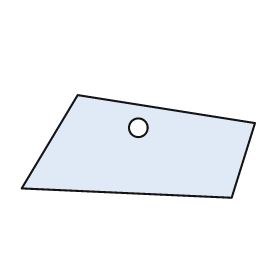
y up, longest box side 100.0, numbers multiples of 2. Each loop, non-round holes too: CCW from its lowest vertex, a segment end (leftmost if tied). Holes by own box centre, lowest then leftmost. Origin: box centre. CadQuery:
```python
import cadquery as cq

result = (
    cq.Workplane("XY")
    .moveTo(40.0, -22.0)
    .lineTo(50.0, 10.0)
    .lineTo(-26.0, 22.0)
    .lineTo(-50.0, -18.0)
    .close()
    .moveTo(0.0, 8.0)
    .circle(4.0)
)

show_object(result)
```